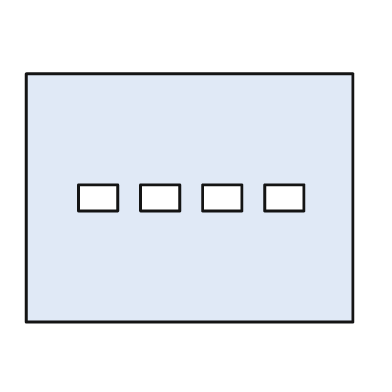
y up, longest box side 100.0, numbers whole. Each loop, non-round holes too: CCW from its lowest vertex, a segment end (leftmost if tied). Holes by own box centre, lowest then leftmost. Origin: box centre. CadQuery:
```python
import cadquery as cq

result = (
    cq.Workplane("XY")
    .moveTo(-50.0, -38.0)
    .lineTo(50.0, -38.0)
    .lineTo(50.0, 38.0)
    .lineTo(-50.0, 38.0)
    .close()
    .moveTo(-34.0, -4.0)
    .lineTo(-22.0, -4.0)
    .lineTo(-22.0, 4.0)
    .lineTo(-34.0, 4.0)
    .close()
    .moveTo(-15.0, -4.0)
    .lineTo(-3.0, -4.0)
    .lineTo(-3.0, 4.0)
    .lineTo(-15.0, 4.0)
    .close()
    .moveTo(4.0, -4.0)
    .lineTo(16.0, -4.0)
    .lineTo(16.0, 4.0)
    .lineTo(4.0, 4.0)
    .close()
    .moveTo(23.0, -4.0)
    .lineTo(35.0, -4.0)
    .lineTo(35.0, 4.0)
    .lineTo(23.0, 4.0)
    .close()
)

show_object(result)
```